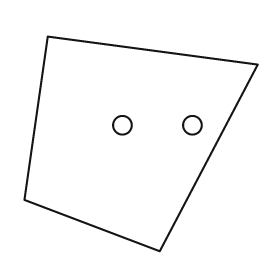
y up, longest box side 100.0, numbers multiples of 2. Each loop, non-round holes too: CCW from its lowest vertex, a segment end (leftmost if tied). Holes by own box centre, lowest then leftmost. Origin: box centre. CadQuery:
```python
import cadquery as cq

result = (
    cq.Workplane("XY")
    .moveTo(8.0, -46.0)
    .lineTo(50.0, 34.0)
    .lineTo(-40.0, 46.0)
    .lineTo(-50.0, -24.0)
    .close()
    .moveTo(-8.0, 8.0)
    .circle(4.0)
    .moveTo(22.0, 8.0)
    .circle(4.0)
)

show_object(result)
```